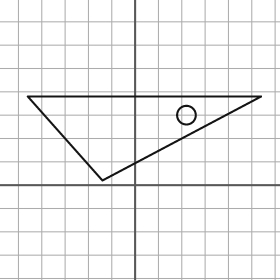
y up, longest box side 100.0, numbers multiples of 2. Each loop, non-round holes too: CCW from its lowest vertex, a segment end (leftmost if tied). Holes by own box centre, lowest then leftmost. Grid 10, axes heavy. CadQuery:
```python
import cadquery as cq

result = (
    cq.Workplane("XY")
    .moveTo(-14.0, 2.0)
    .lineTo(54.0, 38.0)
    .lineTo(-46.0, 38.0)
    .close()
    .moveTo(22.0, 30.0)
    .circle(4.0)
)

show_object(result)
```